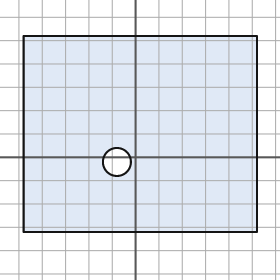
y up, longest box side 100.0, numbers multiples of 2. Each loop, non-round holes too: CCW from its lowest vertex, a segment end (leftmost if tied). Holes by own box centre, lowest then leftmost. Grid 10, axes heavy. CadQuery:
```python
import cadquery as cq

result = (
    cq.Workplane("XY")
    .moveTo(-48.0, -32.0)
    .lineTo(52.0, -32.0)
    .lineTo(52.0, 52.0)
    .lineTo(-48.0, 52.0)
    .close()
    .moveTo(-8.0, -2.0)
    .circle(6.0)
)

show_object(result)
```